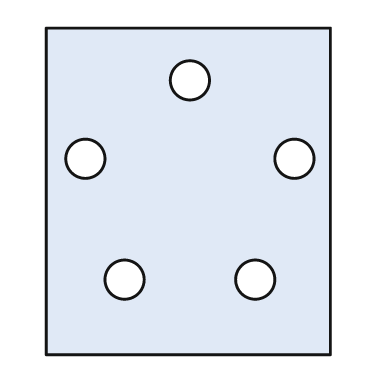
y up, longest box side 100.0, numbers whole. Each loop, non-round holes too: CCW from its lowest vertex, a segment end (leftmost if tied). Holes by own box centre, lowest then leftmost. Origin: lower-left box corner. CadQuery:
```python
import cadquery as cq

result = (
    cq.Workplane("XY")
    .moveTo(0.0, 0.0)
    .lineTo(87.0, 0.0)
    .lineTo(87.0, 100.0)
    .lineTo(0.0, 100.0)
    .close()
    .moveTo(24.0, 23.0)
    .circle(6.0)
    .moveTo(64.0, 23.0)
    .circle(6.0)
    .moveTo(12.0, 60.0)
    .circle(6.0)
    .moveTo(76.0, 60.0)
    .circle(6.0)
    .moveTo(44.0, 84.0)
    .circle(6.0)
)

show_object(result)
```